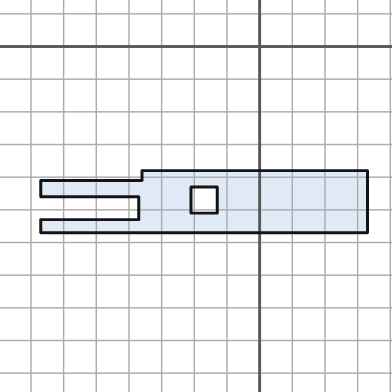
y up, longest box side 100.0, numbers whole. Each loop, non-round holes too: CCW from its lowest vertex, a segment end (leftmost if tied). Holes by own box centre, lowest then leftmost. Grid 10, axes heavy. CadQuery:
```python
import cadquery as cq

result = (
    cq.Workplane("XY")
    .moveTo(-67.0, -57.0)
    .lineTo(33.0, -57.0)
    .lineTo(33.0, -38.0)
    .lineTo(-36.0, -38.0)
    .lineTo(-36.0, -41.0)
    .lineTo(-67.0, -41.0)
    .lineTo(-67.0, -46.0)
    .lineTo(-37.0, -46.0)
    .lineTo(-37.0, -53.0)
    .lineTo(-67.0, -53.0)
    .close()
    .moveTo(-21.0, -51.0)
    .lineTo(-13.0, -51.0)
    .lineTo(-13.0, -43.0)
    .lineTo(-21.0, -43.0)
    .close()
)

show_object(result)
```